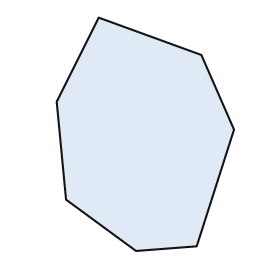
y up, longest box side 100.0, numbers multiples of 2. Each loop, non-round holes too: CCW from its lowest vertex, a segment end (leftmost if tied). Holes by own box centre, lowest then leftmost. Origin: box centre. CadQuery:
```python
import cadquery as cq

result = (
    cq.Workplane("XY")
    .moveTo(-4.0, -50.0)
    .lineTo(22.0, -48.0)
    .lineTo(38.0, 2.0)
    .lineTo(24.0, 34.0)
    .lineTo(-20.0, 50.0)
    .lineTo(-38.0, 14.0)
    .lineTo(-34.0, -28.0)
    .close()
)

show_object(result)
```